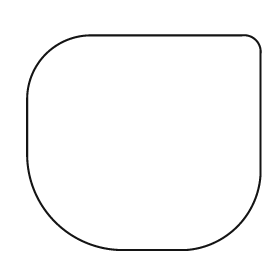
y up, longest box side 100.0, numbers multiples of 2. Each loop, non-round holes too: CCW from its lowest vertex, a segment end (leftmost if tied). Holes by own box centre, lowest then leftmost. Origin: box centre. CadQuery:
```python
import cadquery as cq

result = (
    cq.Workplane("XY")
    .moveTo(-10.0, -46.0)
    .lineTo(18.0, -46.0)
    .threePointArc((40.0, -36.0), (50.0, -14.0))
    .lineTo(50.0, 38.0)
    .threePointArc((48.0, 44.0), (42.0, 46.0))
    .lineTo(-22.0, 46.0)
    .threePointArc((-42.0, 38.0), (-50.0, 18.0))
    .lineTo(-50.0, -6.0)
    .threePointArc((-38.0, -34.0), (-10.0, -46.0))
    .close()
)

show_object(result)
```